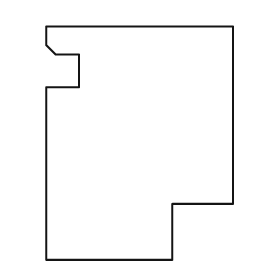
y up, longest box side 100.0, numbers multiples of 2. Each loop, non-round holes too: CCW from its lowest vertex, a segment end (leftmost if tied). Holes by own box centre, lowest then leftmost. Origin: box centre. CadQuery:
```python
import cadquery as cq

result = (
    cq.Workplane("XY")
    .moveTo(-40.0, -50.0)
    .lineTo(14.0, -50.0)
    .lineTo(14.0, -26.0)
    .lineTo(40.0, -26.0)
    .lineTo(40.0, 50.0)
    .lineTo(-40.0, 50.0)
    .lineTo(-40.0, 42.0)
    .lineTo(-36.0, 38.0)
    .lineTo(-26.0, 38.0)
    .lineTo(-26.0, 24.0)
    .lineTo(-40.0, 24.0)
    .close()
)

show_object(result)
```